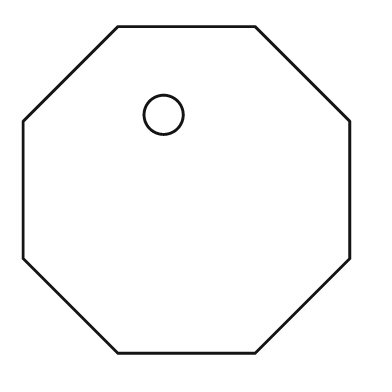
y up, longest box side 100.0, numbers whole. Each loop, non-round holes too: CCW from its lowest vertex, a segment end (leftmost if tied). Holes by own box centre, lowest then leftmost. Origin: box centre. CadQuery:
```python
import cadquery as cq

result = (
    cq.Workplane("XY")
    .moveTo(-21.0, -50.0)
    .lineTo(21.0, -50.0)
    .lineTo(50.0, -21.0)
    .lineTo(50.0, 21.0)
    .lineTo(21.0, 50.0)
    .lineTo(-21.0, 50.0)
    .lineTo(-50.0, 21.0)
    .lineTo(-50.0, -21.0)
    .close()
    .moveTo(-7.0, 23.0)
    .circle(6.0)
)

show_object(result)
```